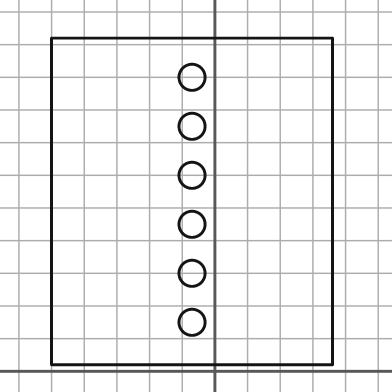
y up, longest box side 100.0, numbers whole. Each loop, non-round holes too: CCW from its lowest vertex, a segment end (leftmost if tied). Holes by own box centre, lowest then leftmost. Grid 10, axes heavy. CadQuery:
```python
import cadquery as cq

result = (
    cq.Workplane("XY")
    .moveTo(-50.0, 2.0)
    .lineTo(36.0, 2.0)
    .lineTo(36.0, 102.0)
    .lineTo(-50.0, 102.0)
    .close()
    .moveTo(-7.0, 15.0)
    .circle(4.0)
    .moveTo(-7.0, 30.0)
    .circle(4.0)
    .moveTo(-7.0, 45.0)
    .circle(4.0)
    .moveTo(-7.0, 60.0)
    .circle(4.0)
    .moveTo(-7.0, 75.0)
    .circle(4.0)
    .moveTo(-7.0, 90.0)
    .circle(4.0)
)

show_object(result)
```